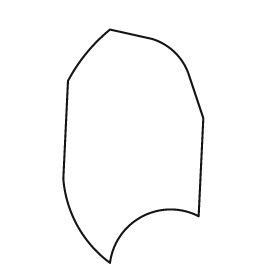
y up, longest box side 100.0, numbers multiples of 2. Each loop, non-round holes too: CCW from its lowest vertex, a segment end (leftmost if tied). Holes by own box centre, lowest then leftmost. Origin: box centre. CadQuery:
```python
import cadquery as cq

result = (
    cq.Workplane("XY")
    .moveTo(-10.0, -50.0)
    .threePointArc((4.0, -30.0), (28.0, -30.0))
    .lineTo(30.0, 12.0)
    .lineTo(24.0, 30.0)
    .threePointArc((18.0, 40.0), (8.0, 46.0))
    .lineTo(-10.0, 50.0)
    .threePointArc((-20.0, 40.0), (-28.0, 28.0))
    .lineTo(-30.0, -14.0)
    .threePointArc((-24.0, -34.0), (-10.0, -50.0))
    .close()
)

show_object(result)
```